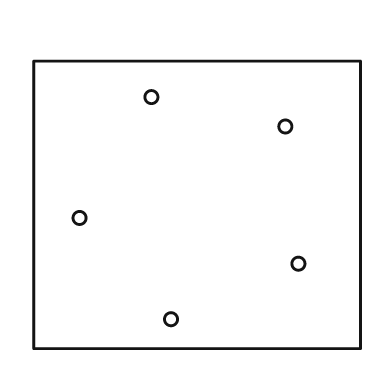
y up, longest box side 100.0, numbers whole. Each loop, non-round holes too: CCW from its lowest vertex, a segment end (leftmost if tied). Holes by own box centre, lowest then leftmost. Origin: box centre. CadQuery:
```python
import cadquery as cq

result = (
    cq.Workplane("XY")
    .moveTo(-50.0, -44.0)
    .lineTo(50.0, -44.0)
    .lineTo(50.0, 44.0)
    .lineTo(-50.0, 44.0)
    .close()
    .moveTo(-8.0, -35.0)
    .circle(2.0)
    .moveTo(31.0, -18.0)
    .circle(2.0)
    .moveTo(-36.0, -4.0)
    .circle(2.0)
    .moveTo(27.0, 24.0)
    .circle(2.0)
    .moveTo(-14.0, 33.0)
    .circle(2.0)
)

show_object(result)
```